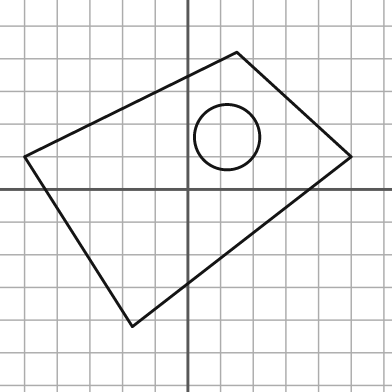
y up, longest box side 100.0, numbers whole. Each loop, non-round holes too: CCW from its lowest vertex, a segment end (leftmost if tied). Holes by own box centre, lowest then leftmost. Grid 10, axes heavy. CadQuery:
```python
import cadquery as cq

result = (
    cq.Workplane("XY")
    .moveTo(-17.0, -42.0)
    .lineTo(50.0, 10.0)
    .lineTo(15.0, 42.0)
    .lineTo(-50.0, 10.0)
    .close()
    .moveTo(12.0, 16.0)
    .circle(10.0)
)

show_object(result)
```